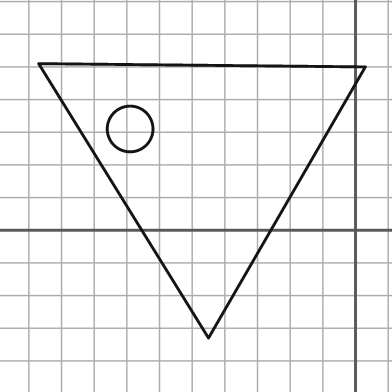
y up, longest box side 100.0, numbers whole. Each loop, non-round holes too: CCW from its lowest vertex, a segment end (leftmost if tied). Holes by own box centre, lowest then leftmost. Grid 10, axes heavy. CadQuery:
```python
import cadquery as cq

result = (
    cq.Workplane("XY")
    .moveTo(-45.0, -33.0)
    .lineTo(3.0, 50.0)
    .lineTo(-97.0, 51.0)
    .close()
    .moveTo(-69.0, 31.0)
    .circle(7.0)
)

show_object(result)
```